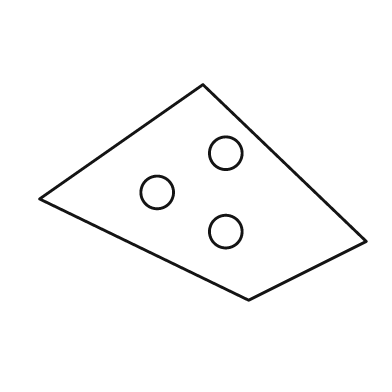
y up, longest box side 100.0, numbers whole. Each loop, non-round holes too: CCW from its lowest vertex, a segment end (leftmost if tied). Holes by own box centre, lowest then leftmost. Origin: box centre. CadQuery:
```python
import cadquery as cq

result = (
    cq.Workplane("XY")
    .moveTo(14.0, -33.0)
    .lineTo(50.0, -15.0)
    .lineTo(0.0, 33.0)
    .lineTo(-50.0, -2.0)
    .close()
    .moveTo(7.0, -12.0)
    .circle(5.0)
    .moveTo(-14.0, 0.0)
    .circle(5.0)
    .moveTo(7.0, 12.0)
    .circle(5.0)
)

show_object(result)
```